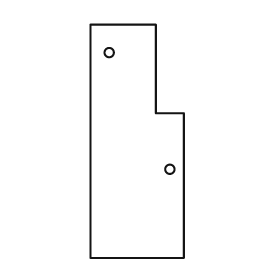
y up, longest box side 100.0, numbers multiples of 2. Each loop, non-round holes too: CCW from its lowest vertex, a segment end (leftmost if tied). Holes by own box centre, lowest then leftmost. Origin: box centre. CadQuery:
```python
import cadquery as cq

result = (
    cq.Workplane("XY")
    .moveTo(-20.0, -50.0)
    .lineTo(20.0, -50.0)
    .lineTo(20.0, 12.0)
    .lineTo(8.0, 12.0)
    .lineTo(8.0, 50.0)
    .lineTo(-20.0, 50.0)
    .close()
    .moveTo(14.0, -12.0)
    .circle(2.0)
    .moveTo(-12.0, 38.0)
    .circle(2.0)
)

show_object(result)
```